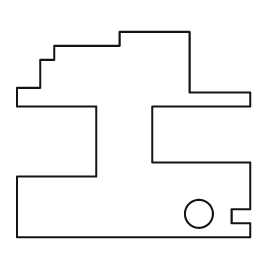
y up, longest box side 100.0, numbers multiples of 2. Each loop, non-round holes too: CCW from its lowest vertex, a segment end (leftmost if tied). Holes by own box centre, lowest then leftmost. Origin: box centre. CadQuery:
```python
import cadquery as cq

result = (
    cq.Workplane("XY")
    .moveTo(-50.0, -44.0)
    .lineTo(50.0, -44.0)
    .lineTo(50.0, -38.0)
    .lineTo(42.0, -38.0)
    .lineTo(42.0, -32.0)
    .lineTo(50.0, -32.0)
    .lineTo(50.0, -12.0)
    .lineTo(8.0, -12.0)
    .lineTo(8.0, 12.0)
    .lineTo(50.0, 12.0)
    .lineTo(50.0, 18.0)
    .lineTo(24.0, 18.0)
    .lineTo(24.0, 44.0)
    .lineTo(-6.0, 44.0)
    .lineTo(-6.0, 38.0)
    .lineTo(-34.0, 38.0)
    .lineTo(-34.0, 32.0)
    .lineTo(-40.0, 32.0)
    .lineTo(-40.0, 20.0)
    .lineTo(-50.0, 20.0)
    .lineTo(-50.0, 12.0)
    .lineTo(-16.0, 12.0)
    .lineTo(-16.0, -18.0)
    .lineTo(-50.0, -18.0)
    .close()
    .moveTo(28.0, -34.0)
    .circle(6.0)
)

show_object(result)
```